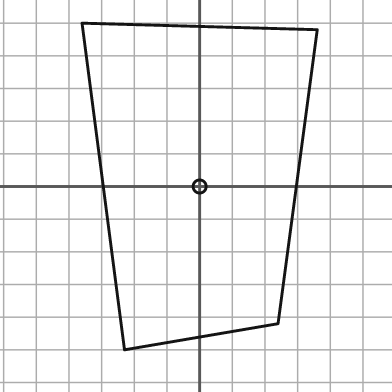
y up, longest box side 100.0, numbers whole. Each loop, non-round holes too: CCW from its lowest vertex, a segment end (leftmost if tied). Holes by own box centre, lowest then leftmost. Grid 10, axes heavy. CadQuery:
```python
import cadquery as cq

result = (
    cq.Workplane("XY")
    .moveTo(-23.0, -50.0)
    .lineTo(24.0, -42.0)
    .lineTo(36.0, 48.0)
    .lineTo(-36.0, 50.0)
    .close()
    .moveTo(0.0, 0.0)
    .circle(2.0)
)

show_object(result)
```